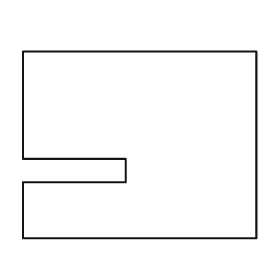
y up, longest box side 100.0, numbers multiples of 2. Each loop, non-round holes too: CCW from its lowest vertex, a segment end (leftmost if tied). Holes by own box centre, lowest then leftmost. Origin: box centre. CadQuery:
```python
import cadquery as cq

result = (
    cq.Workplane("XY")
    .moveTo(-50.0, -40.0)
    .lineTo(50.0, -40.0)
    .lineTo(50.0, 40.0)
    .lineTo(-50.0, 40.0)
    .lineTo(-50.0, -6.0)
    .lineTo(-6.0, -6.0)
    .lineTo(-6.0, -16.0)
    .lineTo(-50.0, -16.0)
    .close()
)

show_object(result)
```